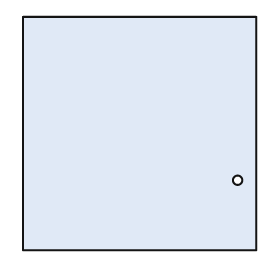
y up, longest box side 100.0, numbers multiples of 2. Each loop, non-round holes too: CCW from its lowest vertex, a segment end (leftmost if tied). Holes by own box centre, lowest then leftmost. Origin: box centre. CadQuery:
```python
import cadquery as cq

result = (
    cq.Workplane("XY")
    .moveTo(-50.0, -50.0)
    .lineTo(50.0, -50.0)
    .lineTo(50.0, 50.0)
    .lineTo(-50.0, 50.0)
    .close()
    .moveTo(42.0, -20.0)
    .circle(2.0)
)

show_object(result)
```